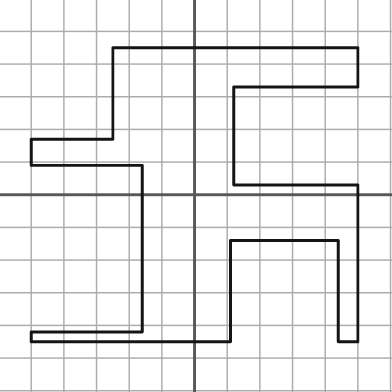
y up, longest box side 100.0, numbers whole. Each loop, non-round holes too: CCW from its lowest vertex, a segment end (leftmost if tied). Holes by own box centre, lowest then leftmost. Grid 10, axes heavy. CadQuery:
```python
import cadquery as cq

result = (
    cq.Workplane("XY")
    .moveTo(-50.0, -45.0)
    .lineTo(11.0, -45.0)
    .lineTo(11.0, -14.0)
    .lineTo(44.0, -14.0)
    .lineTo(44.0, -45.0)
    .lineTo(50.0, -45.0)
    .lineTo(50.0, 3.0)
    .lineTo(12.0, 3.0)
    .lineTo(12.0, 33.0)
    .lineTo(50.0, 33.0)
    .lineTo(50.0, 45.0)
    .lineTo(-25.0, 45.0)
    .lineTo(-25.0, 17.0)
    .lineTo(-50.0, 17.0)
    .lineTo(-50.0, 9.0)
    .lineTo(-16.0, 9.0)
    .lineTo(-16.0, -42.0)
    .lineTo(-50.0, -42.0)
    .close()
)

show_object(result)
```